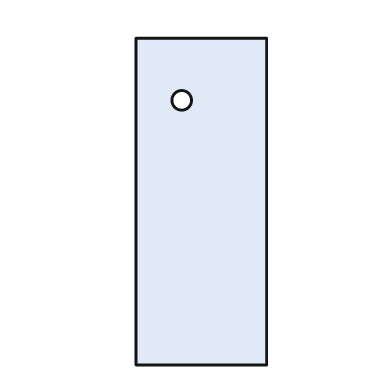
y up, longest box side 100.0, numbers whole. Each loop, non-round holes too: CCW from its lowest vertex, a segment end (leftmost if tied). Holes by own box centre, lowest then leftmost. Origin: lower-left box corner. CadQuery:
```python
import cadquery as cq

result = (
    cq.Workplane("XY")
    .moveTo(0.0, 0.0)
    .lineTo(40.0, 0.0)
    .lineTo(40.0, 100.0)
    .lineTo(0.0, 100.0)
    .close()
    .moveTo(14.0, 81.0)
    .circle(3.0)
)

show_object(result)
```